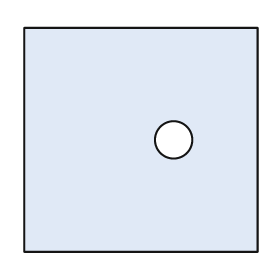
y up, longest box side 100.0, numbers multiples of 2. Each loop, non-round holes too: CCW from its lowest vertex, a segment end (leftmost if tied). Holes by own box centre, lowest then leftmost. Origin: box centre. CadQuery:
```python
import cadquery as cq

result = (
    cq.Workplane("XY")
    .moveTo(-50.0, -48.0)
    .lineTo(50.0, -48.0)
    .lineTo(50.0, 48.0)
    .lineTo(-50.0, 48.0)
    .close()
    .moveTo(14.0, 0.0)
    .circle(8.0)
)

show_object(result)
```